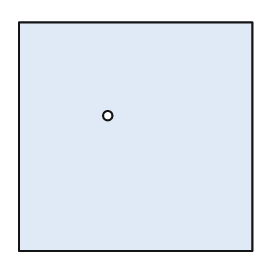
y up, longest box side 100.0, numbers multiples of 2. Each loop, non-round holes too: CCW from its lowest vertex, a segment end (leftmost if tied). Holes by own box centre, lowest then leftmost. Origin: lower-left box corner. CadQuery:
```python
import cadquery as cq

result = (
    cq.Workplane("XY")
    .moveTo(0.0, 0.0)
    .lineTo(100.0, 0.0)
    .lineTo(100.0, 98.0)
    .lineTo(0.0, 98.0)
    .close()
    .moveTo(38.0, 58.0)
    .circle(2.0)
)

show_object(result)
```